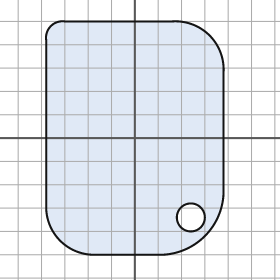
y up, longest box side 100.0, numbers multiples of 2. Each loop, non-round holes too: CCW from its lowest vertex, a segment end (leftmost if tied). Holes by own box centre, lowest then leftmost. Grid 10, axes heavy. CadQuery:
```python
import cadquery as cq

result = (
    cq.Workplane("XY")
    .moveTo(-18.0, -50.0)
    .lineTo(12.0, -50.0)
    .threePointArc((30.0, -42.0), (38.0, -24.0))
    .lineTo(38.0, 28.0)
    .threePointArc((32.0, 44.0), (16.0, 50.0))
    .lineTo(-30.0, 50.0)
    .threePointArc((-36.0, 48.0), (-38.0, 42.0))
    .lineTo(-38.0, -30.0)
    .threePointArc((-32.0, -44.0), (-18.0, -50.0))
    .close()
    .moveTo(24.0, -34.0)
    .circle(6.0)
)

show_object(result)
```